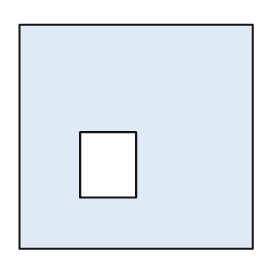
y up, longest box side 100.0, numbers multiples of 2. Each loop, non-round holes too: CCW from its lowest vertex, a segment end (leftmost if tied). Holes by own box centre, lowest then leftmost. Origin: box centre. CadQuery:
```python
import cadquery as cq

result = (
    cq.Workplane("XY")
    .moveTo(-50.0, -48.0)
    .lineTo(50.0, -48.0)
    .lineTo(50.0, 48.0)
    .lineTo(-50.0, 48.0)
    .close()
    .moveTo(-24.0, -26.0)
    .lineTo(0.0, -26.0)
    .lineTo(0.0, 2.0)
    .lineTo(-24.0, 2.0)
    .close()
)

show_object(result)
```